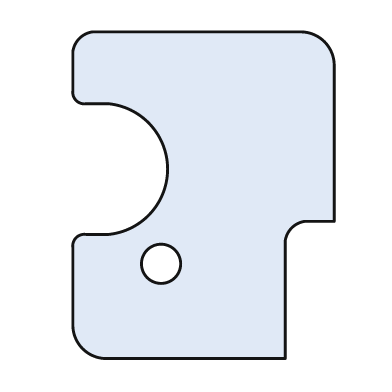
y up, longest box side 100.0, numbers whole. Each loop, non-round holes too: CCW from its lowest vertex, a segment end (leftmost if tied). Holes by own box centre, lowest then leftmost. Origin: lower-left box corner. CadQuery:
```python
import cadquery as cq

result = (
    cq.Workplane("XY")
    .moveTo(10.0, 0.0)
    .lineTo(65.0, 0.0)
    .lineTo(65.0, 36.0)
    .threePointArc((67.0, 40.0), (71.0, 42.0))
    .lineTo(80.0, 42.0)
    .lineTo(80.0, 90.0)
    .threePointArc((77.0, 97.0), (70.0, 100.0))
    .lineTo(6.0, 100.0)
    .threePointArc((2.0, 98.0), (0.0, 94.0))
    .lineTo(0.0, 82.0)
    .threePointArc((1.0, 79.0), (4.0, 78.0))
    .lineTo(11.0, 78.0)
    .threePointArc((29.0, 58.0), (11.0, 38.0))
    .lineTo(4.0, 38.0)
    .threePointArc((1.0, 37.0), (0.0, 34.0))
    .lineTo(0.0, 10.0)
    .threePointArc((3.0, 3.0), (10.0, 0.0))
    .close()
    .moveTo(27.0, 29.0)
    .circle(6.0)
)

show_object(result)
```